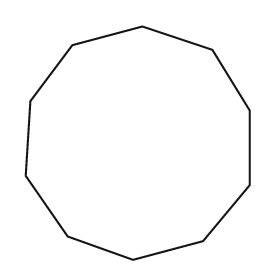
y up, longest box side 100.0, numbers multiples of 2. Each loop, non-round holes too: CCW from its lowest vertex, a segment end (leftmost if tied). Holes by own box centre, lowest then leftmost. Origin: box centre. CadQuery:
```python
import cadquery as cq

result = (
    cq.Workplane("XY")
    .moveTo(-2.0, -50.0)
    .lineTo(28.0, -42.0)
    .lineTo(48.0, -18.0)
    .lineTo(48.0, 14.0)
    .lineTo(32.0, 40.0)
    .lineTo(2.0, 50.0)
    .lineTo(-28.0, 42.0)
    .lineTo(-46.0, 18.0)
    .lineTo(-48.0, -14.0)
    .lineTo(-30.0, -40.0)
    .close()
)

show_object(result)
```